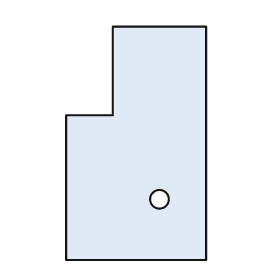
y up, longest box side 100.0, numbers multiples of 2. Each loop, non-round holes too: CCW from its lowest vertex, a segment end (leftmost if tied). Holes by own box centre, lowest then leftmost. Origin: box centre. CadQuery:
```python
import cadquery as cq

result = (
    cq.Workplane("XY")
    .moveTo(-30.0, -50.0)
    .lineTo(30.0, -50.0)
    .lineTo(30.0, 50.0)
    .lineTo(-10.0, 50.0)
    .lineTo(-10.0, 12.0)
    .lineTo(-30.0, 12.0)
    .close()
    .moveTo(10.0, -24.0)
    .circle(4.0)
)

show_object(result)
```